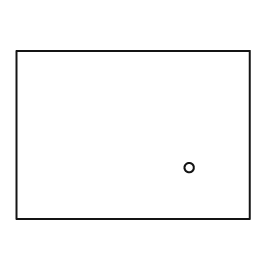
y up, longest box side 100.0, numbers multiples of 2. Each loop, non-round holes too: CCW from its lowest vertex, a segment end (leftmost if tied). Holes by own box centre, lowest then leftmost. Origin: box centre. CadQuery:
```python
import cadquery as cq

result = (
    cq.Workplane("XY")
    .moveTo(-50.0, -36.0)
    .lineTo(50.0, -36.0)
    .lineTo(50.0, 36.0)
    .lineTo(-50.0, 36.0)
    .close()
    .moveTo(24.0, -14.0)
    .circle(2.0)
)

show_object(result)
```